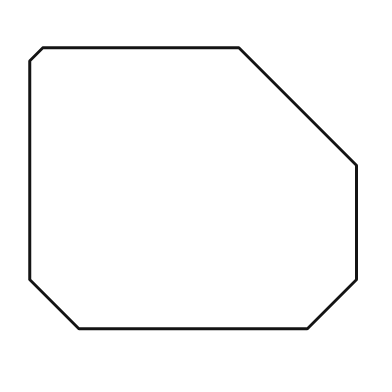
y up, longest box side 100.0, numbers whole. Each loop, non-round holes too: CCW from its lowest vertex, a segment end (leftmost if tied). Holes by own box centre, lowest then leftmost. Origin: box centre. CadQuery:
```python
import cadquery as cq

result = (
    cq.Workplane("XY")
    .moveTo(-35.0, -43.0)
    .lineTo(35.0, -43.0)
    .lineTo(50.0, -28.0)
    .lineTo(50.0, 7.0)
    .lineTo(14.0, 43.0)
    .lineTo(-46.0, 43.0)
    .lineTo(-50.0, 39.0)
    .lineTo(-50.0, -28.0)
    .close()
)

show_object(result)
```